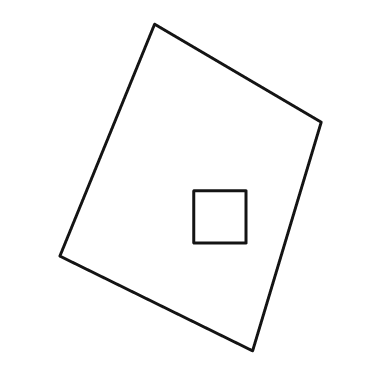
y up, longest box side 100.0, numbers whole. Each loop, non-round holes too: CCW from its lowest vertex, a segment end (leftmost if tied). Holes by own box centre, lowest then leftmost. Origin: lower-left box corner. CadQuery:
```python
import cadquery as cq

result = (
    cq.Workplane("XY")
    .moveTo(59.0, 0.0)
    .lineTo(80.0, 70.0)
    .lineTo(29.0, 100.0)
    .lineTo(0.0, 29.0)
    .close()
    .moveTo(41.0, 33.0)
    .lineTo(57.0, 33.0)
    .lineTo(57.0, 49.0)
    .lineTo(41.0, 49.0)
    .close()
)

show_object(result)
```